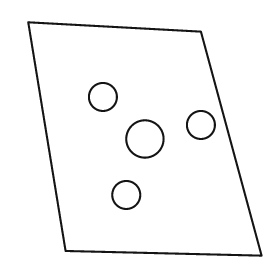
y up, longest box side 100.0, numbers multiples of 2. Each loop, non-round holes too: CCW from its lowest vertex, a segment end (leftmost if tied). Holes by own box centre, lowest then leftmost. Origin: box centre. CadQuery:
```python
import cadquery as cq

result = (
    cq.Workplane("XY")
    .moveTo(50.0, -50.0)
    .lineTo(24.0, 46.0)
    .lineTo(-50.0, 50.0)
    .lineTo(-34.0, -48.0)
    .close()
    .moveTo(-8.0, -24.0)
    .circle(6.0)
    .moveTo(0.0, 0.0)
    .circle(8.0)
    .moveTo(24.0, 6.0)
    .circle(6.0)
    .moveTo(-18.0, 18.0)
    .circle(6.0)
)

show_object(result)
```